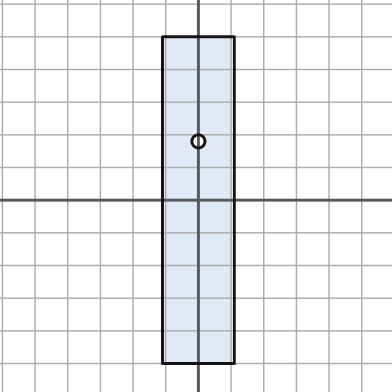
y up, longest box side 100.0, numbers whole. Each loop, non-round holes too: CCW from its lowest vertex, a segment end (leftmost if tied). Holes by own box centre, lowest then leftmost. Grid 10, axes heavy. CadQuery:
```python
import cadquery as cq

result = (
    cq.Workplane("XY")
    .moveTo(-11.0, -50.0)
    .lineTo(11.0, -50.0)
    .lineTo(11.0, 50.0)
    .lineTo(-11.0, 50.0)
    .close()
    .moveTo(0.0, 18.0)
    .circle(2.0)
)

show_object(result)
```